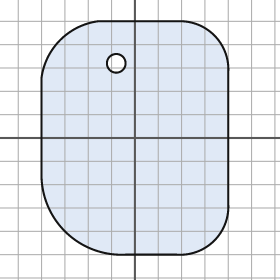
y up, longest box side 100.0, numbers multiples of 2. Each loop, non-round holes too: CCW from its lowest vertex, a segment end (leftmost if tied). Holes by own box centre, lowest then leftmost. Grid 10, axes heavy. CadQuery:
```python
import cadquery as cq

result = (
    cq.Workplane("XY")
    .moveTo(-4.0, -50.0)
    .lineTo(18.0, -50.0)
    .threePointArc((34.0, -44.0), (40.0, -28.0))
    .lineTo(40.0, 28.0)
    .threePointArc((34.0, 44.0), (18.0, 50.0))
    .lineTo(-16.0, 50.0)
    .threePointArc((-32.0, 42.0), (-40.0, 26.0))
    .lineTo(-40.0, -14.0)
    .threePointArc((-30.0, -40.0), (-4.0, -50.0))
    .close()
    .moveTo(-8.0, 32.0)
    .circle(4.0)
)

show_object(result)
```